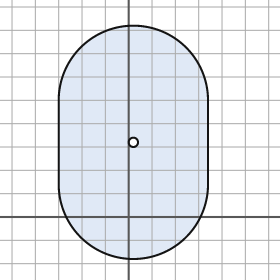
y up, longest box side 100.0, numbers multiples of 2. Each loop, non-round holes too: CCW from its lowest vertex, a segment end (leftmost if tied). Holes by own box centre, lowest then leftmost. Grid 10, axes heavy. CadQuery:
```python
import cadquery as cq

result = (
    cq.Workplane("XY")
    .moveTo(-30.0, 14.0)
    .threePointArc((2.0, -18.0), (34.0, 14.0))
    .lineTo(34.0, 50.0)
    .threePointArc((2.0, 82.0), (-30.0, 50.0))
    .close()
    .moveTo(2.0, 32.0)
    .circle(2.0)
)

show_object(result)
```